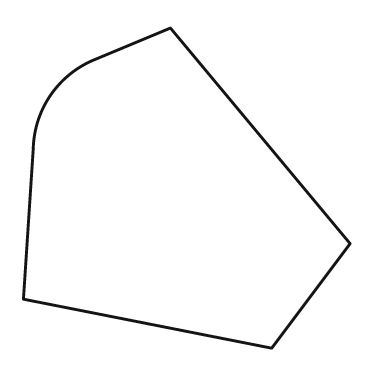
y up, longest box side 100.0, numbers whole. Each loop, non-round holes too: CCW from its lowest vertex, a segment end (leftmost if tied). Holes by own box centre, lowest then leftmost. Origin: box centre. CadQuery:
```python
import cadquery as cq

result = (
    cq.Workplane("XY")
    .moveTo(26.0, -49.0)
    .lineTo(50.0, -17.0)
    .lineTo(-5.0, 49.0)
    .lineTo(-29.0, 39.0)
    .threePointArc((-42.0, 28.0), (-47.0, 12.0))
    .lineTo(-50.0, -34.0)
    .close()
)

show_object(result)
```